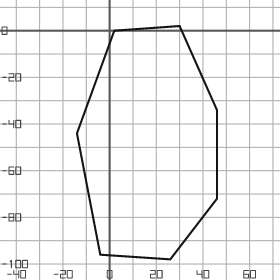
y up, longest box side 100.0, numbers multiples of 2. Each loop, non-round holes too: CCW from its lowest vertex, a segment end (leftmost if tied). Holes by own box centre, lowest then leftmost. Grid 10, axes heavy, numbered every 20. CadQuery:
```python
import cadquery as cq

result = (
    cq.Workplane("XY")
    .moveTo(26.0, -98.0)
    .lineTo(46.0, -72.0)
    .lineTo(46.0, -34.0)
    .lineTo(30.0, 2.0)
    .lineTo(2.0, 0.0)
    .lineTo(-14.0, -44.0)
    .lineTo(-4.0, -96.0)
    .close()
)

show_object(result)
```